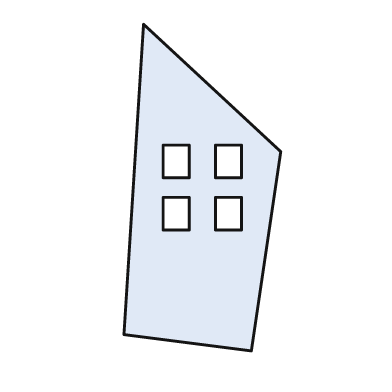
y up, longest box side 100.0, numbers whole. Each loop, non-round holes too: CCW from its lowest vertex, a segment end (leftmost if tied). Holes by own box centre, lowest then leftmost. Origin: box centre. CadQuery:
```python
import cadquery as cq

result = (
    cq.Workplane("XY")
    .moveTo(15.0, -50.0)
    .lineTo(24.0, 11.0)
    .lineTo(-18.0, 50.0)
    .lineTo(-24.0, -45.0)
    .close()
    .moveTo(-12.0, -13.0)
    .lineTo(-4.0, -13.0)
    .lineTo(-4.0, -3.0)
    .lineTo(-12.0, -3.0)
    .close()
    .moveTo(4.0, -13.0)
    .lineTo(12.0, -13.0)
    .lineTo(12.0, -3.0)
    .lineTo(4.0, -3.0)
    .close()
    .moveTo(-12.0, 3.0)
    .lineTo(-4.0, 3.0)
    .lineTo(-4.0, 13.0)
    .lineTo(-12.0, 13.0)
    .close()
    .moveTo(4.0, 3.0)
    .lineTo(12.0, 3.0)
    .lineTo(12.0, 13.0)
    .lineTo(4.0, 13.0)
    .close()
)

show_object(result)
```